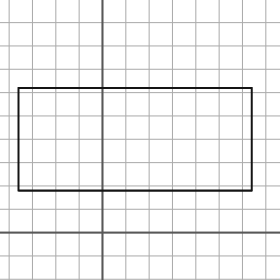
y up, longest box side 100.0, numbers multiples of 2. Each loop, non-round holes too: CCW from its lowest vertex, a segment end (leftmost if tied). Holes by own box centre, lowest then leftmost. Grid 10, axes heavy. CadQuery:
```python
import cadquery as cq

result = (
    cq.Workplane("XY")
    .moveTo(-36.0, 18.0)
    .lineTo(64.0, 18.0)
    .lineTo(64.0, 62.0)
    .lineTo(-36.0, 62.0)
    .close()
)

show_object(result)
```